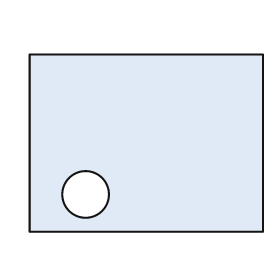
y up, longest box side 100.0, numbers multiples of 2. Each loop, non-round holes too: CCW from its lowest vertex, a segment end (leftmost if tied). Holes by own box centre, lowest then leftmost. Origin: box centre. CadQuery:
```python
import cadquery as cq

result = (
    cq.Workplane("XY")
    .moveTo(-50.0, -38.0)
    .lineTo(50.0, -38.0)
    .lineTo(50.0, 38.0)
    .lineTo(-50.0, 38.0)
    .close()
    .moveTo(-26.0, -22.0)
    .circle(10.0)
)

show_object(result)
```